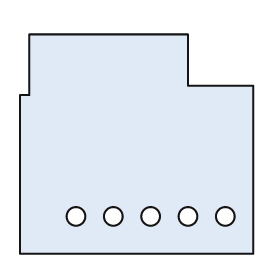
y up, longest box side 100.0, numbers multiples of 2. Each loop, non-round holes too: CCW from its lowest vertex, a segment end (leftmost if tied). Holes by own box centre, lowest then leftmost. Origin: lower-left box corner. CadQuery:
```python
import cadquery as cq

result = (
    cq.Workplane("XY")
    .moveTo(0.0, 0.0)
    .lineTo(100.0, 0.0)
    .lineTo(100.0, 72.0)
    .lineTo(72.0, 72.0)
    .lineTo(72.0, 94.0)
    .lineTo(4.0, 94.0)
    .lineTo(4.0, 68.0)
    .lineTo(0.0, 68.0)
    .close()
    .moveTo(24.0, 16.0)
    .circle(4.0)
    .moveTo(40.0, 16.0)
    .circle(4.0)
    .moveTo(56.0, 16.0)
    .circle(4.0)
    .moveTo(72.0, 16.0)
    .circle(4.0)
    .moveTo(88.0, 16.0)
    .circle(4.0)
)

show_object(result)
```